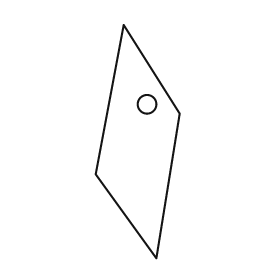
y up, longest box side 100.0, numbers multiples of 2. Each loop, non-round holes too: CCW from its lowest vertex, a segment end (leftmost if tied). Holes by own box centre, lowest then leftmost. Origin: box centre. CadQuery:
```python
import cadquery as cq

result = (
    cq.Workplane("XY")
    .moveTo(8.0, -50.0)
    .lineTo(18.0, 12.0)
    .lineTo(-6.0, 50.0)
    .lineTo(-18.0, -14.0)
    .close()
    .moveTo(4.0, 16.0)
    .circle(4.0)
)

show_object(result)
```